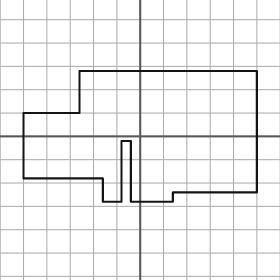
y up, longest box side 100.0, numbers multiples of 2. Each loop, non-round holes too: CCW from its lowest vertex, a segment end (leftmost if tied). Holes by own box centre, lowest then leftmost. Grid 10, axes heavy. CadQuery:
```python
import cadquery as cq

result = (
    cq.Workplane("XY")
    .moveTo(-16.0, -28.0)
    .lineTo(-8.0, -28.0)
    .lineTo(-8.0, -2.0)
    .lineTo(-4.0, -2.0)
    .lineTo(-4.0, -28.0)
    .lineTo(14.0, -28.0)
    .lineTo(14.0, -24.0)
    .lineTo(50.0, -24.0)
    .lineTo(50.0, 28.0)
    .lineTo(-26.0, 28.0)
    .lineTo(-26.0, 10.0)
    .lineTo(-50.0, 10.0)
    .lineTo(-50.0, -18.0)
    .lineTo(-16.0, -18.0)
    .close()
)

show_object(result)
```